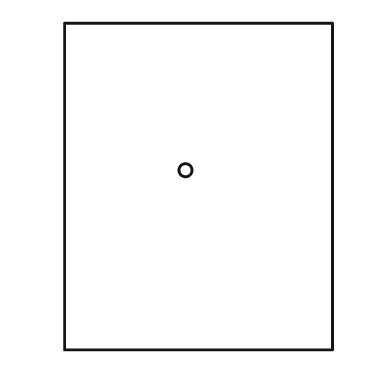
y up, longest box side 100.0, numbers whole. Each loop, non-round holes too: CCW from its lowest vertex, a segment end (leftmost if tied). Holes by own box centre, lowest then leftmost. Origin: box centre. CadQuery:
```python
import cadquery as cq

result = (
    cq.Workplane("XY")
    .moveTo(-41.0, -50.0)
    .lineTo(41.0, -50.0)
    .lineTo(41.0, 50.0)
    .lineTo(-41.0, 50.0)
    .close()
    .moveTo(-4.0, 5.0)
    .circle(2.0)
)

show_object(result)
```